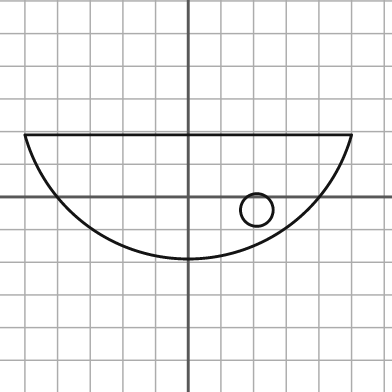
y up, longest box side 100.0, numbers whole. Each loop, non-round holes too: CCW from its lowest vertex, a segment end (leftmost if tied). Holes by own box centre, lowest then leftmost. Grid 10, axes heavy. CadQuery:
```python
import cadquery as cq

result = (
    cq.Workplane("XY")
    .moveTo(-50.0, 19.0)
    .threePointArc((0.0, -19.0), (50.0, 19.0))
    .close()
    .moveTo(21.0, -4.0)
    .circle(5.0)
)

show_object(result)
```